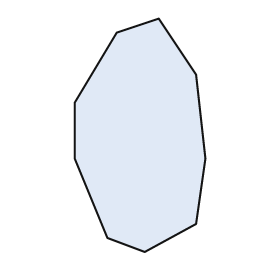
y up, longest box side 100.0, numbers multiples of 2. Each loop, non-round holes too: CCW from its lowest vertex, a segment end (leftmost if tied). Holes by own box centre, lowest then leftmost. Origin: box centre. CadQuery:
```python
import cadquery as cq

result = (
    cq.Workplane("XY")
    .moveTo(2.0, -50.0)
    .lineTo(24.0, -38.0)
    .lineTo(28.0, -10.0)
    .lineTo(24.0, 26.0)
    .lineTo(8.0, 50.0)
    .lineTo(-10.0, 44.0)
    .lineTo(-28.0, 14.0)
    .lineTo(-28.0, -10.0)
    .lineTo(-14.0, -44.0)
    .close()
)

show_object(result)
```